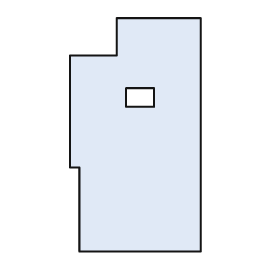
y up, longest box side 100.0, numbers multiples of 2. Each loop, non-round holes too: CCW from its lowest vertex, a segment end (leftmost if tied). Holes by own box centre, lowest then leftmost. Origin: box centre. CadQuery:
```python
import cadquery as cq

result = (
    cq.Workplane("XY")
    .moveTo(-24.0, -50.0)
    .lineTo(28.0, -50.0)
    .lineTo(28.0, 50.0)
    .lineTo(-8.0, 50.0)
    .lineTo(-8.0, 34.0)
    .lineTo(-28.0, 34.0)
    .lineTo(-28.0, -14.0)
    .lineTo(-24.0, -14.0)
    .close()
    .moveTo(-4.0, 12.0)
    .lineTo(8.0, 12.0)
    .lineTo(8.0, 20.0)
    .lineTo(-4.0, 20.0)
    .close()
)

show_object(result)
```